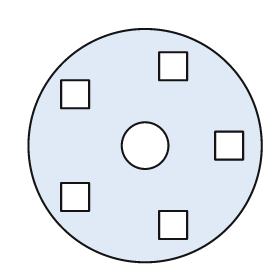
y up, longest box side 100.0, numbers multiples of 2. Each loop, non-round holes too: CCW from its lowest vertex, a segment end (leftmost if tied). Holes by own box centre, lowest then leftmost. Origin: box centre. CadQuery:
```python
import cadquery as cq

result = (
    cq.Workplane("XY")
    .moveTo(0.0, 0.0)
    .circle(50.0)
    .moveTo(6.0, -40.0)
    .lineTo(18.0, -40.0)
    .lineTo(18.0, -28.0)
    .lineTo(6.0, -28.0)
    .close()
    .moveTo(-36.0, -28.0)
    .lineTo(-24.0, -28.0)
    .lineTo(-24.0, -16.0)
    .lineTo(-36.0, -16.0)
    .close()
    .moveTo(0.0, 0.0)
    .circle(10.0)
    .moveTo(30.0, -6.0)
    .lineTo(42.0, -6.0)
    .lineTo(42.0, 6.0)
    .lineTo(30.0, 6.0)
    .close()
    .moveTo(-36.0, 16.0)
    .lineTo(-24.0, 16.0)
    .lineTo(-24.0, 28.0)
    .lineTo(-36.0, 28.0)
    .close()
    .moveTo(6.0, 28.0)
    .lineTo(18.0, 28.0)
    .lineTo(18.0, 40.0)
    .lineTo(6.0, 40.0)
    .close()
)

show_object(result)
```